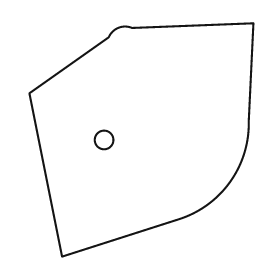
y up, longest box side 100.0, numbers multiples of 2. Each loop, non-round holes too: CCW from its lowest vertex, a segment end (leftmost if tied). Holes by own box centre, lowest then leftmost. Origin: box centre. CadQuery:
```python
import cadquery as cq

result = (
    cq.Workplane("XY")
    .moveTo(-34.0, -50.0)
    .lineTo(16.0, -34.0)
    .threePointArc((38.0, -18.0), (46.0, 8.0))
    .lineTo(48.0, 50.0)
    .lineTo(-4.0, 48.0)
    .threePointArc((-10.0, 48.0), (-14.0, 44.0))
    .lineTo(-48.0, 20.0)
    .close()
    .moveTo(-16.0, 0.0)
    .circle(4.0)
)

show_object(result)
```